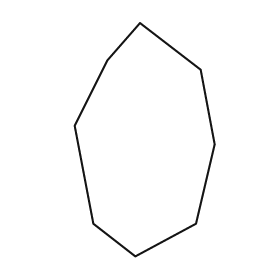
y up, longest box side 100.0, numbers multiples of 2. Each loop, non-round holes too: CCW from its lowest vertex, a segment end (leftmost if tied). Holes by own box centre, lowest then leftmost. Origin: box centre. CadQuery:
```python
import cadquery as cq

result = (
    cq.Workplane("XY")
    .moveTo(-4.0, -50.0)
    .lineTo(22.0, -36.0)
    .lineTo(30.0, -2.0)
    .lineTo(24.0, 30.0)
    .lineTo(-2.0, 50.0)
    .lineTo(-16.0, 34.0)
    .lineTo(-30.0, 6.0)
    .lineTo(-22.0, -36.0)
    .close()
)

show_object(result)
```